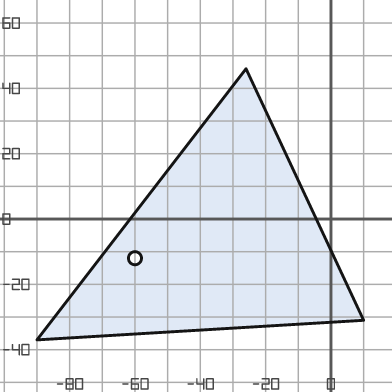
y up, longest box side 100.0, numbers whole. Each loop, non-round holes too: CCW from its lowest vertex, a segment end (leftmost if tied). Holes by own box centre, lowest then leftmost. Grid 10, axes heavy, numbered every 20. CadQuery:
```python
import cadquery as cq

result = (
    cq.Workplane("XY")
    .moveTo(-90.0, -37.0)
    .lineTo(10.0, -31.0)
    .lineTo(-26.0, 46.0)
    .close()
    .moveTo(-60.0, -12.0)
    .circle(2.0)
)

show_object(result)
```